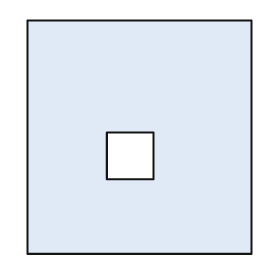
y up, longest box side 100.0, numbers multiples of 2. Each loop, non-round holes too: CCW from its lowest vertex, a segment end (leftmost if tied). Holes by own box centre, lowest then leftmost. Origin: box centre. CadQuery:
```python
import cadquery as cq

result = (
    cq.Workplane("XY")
    .moveTo(-48.0, -50.0)
    .lineTo(48.0, -50.0)
    .lineTo(48.0, 50.0)
    .lineTo(-48.0, 50.0)
    .close()
    .moveTo(-14.0, -18.0)
    .lineTo(6.0, -18.0)
    .lineTo(6.0, 2.0)
    .lineTo(-14.0, 2.0)
    .close()
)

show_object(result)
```